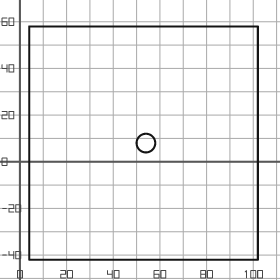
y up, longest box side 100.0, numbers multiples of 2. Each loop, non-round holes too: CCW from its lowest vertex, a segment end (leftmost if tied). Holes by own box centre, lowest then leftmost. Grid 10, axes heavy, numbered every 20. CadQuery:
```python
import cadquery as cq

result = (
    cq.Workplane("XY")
    .moveTo(4.0, -42.0)
    .lineTo(102.0, -42.0)
    .lineTo(102.0, 58.0)
    .lineTo(4.0, 58.0)
    .close()
    .moveTo(54.0, 8.0)
    .circle(4.0)
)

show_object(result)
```